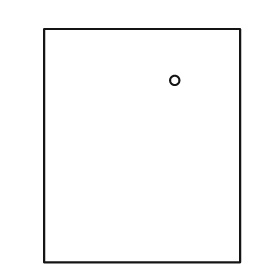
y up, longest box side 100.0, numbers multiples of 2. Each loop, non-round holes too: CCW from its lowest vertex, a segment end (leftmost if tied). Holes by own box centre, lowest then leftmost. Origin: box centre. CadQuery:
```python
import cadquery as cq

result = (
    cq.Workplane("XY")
    .moveTo(-42.0, -50.0)
    .lineTo(42.0, -50.0)
    .lineTo(42.0, 50.0)
    .lineTo(-42.0, 50.0)
    .close()
    .moveTo(14.0, 28.0)
    .circle(2.0)
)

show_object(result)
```